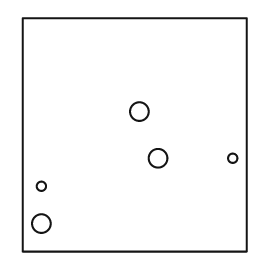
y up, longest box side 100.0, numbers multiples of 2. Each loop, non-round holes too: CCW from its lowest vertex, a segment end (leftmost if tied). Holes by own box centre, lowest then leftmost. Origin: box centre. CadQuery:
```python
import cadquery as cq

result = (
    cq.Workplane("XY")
    .moveTo(-48.0, -50.0)
    .lineTo(48.0, -50.0)
    .lineTo(48.0, 50.0)
    .lineTo(-48.0, 50.0)
    .close()
    .moveTo(-40.0, -38.0)
    .circle(4.0)
    .moveTo(-40.0, -22.0)
    .circle(2.0)
    .moveTo(10.0, -10.0)
    .circle(4.0)
    .moveTo(42.0, -10.0)
    .circle(2.0)
    .moveTo(2.0, 10.0)
    .circle(4.0)
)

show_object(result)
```